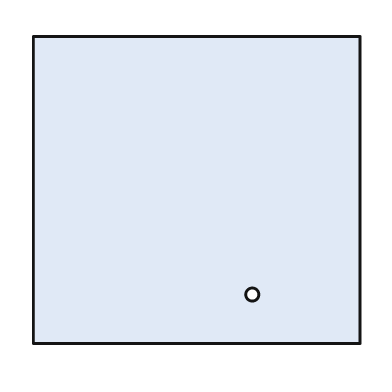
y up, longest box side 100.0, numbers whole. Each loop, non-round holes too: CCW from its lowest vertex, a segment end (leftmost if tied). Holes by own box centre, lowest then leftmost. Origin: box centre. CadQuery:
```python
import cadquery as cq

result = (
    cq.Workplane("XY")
    .moveTo(-50.0, -47.0)
    .lineTo(50.0, -47.0)
    .lineTo(50.0, 47.0)
    .lineTo(-50.0, 47.0)
    .close()
    .moveTo(17.0, -32.0)
    .circle(2.0)
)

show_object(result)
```